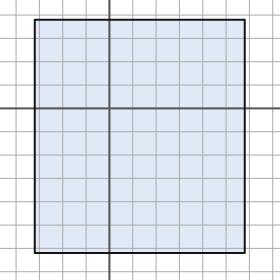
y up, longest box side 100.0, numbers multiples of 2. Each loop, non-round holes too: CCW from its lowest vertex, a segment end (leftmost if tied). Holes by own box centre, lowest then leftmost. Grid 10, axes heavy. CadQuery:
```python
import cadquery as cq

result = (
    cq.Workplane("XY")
    .moveTo(-32.0, -62.0)
    .lineTo(58.0, -62.0)
    .lineTo(58.0, 38.0)
    .lineTo(-32.0, 38.0)
    .close()
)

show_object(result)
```